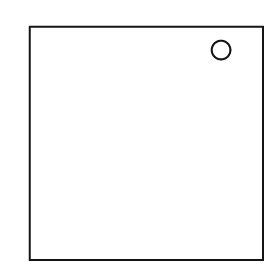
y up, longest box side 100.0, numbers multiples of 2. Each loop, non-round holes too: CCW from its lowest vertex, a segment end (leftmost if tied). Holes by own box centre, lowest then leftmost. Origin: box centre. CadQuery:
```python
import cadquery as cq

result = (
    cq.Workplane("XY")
    .moveTo(-50.0, -50.0)
    .lineTo(50.0, -50.0)
    .lineTo(50.0, 50.0)
    .lineTo(-50.0, 50.0)
    .close()
    .moveTo(32.0, 40.0)
    .circle(4.0)
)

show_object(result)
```